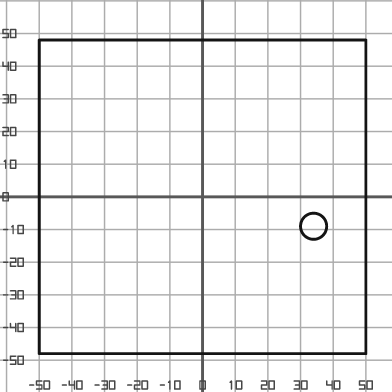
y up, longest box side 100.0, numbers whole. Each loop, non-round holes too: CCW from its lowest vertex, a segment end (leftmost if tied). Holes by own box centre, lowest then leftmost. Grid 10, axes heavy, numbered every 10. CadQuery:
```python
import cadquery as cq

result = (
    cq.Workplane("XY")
    .moveTo(-50.0, -48.0)
    .lineTo(50.0, -48.0)
    .lineTo(50.0, 48.0)
    .lineTo(-50.0, 48.0)
    .close()
    .moveTo(34.0, -9.0)
    .circle(4.0)
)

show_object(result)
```